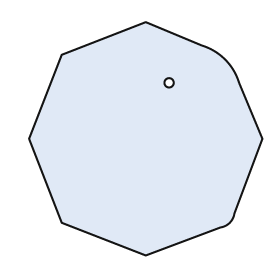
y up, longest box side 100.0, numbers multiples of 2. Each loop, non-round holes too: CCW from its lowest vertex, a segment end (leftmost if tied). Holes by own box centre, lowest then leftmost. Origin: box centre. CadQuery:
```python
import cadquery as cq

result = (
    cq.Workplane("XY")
    .moveTo(0.0, -50.0)
    .lineTo(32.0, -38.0)
    .threePointArc((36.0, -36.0), (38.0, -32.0))
    .lineTo(50.0, 0.0)
    .lineTo(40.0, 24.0)
    .threePointArc((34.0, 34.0), (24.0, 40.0))
    .lineTo(0.0, 50.0)
    .lineTo(-36.0, 36.0)
    .lineTo(-50.0, 0.0)
    .lineTo(-36.0, -36.0)
    .close()
    .moveTo(10.0, 24.0)
    .circle(2.0)
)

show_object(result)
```